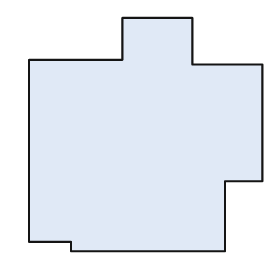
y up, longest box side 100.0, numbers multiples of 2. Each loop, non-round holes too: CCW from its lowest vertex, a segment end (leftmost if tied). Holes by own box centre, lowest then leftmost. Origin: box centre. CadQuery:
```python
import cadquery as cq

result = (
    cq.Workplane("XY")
    .moveTo(-32.0, -50.0)
    .lineTo(34.0, -50.0)
    .lineTo(34.0, -20.0)
    .lineTo(50.0, -20.0)
    .lineTo(50.0, 30.0)
    .lineTo(20.0, 30.0)
    .lineTo(20.0, 50.0)
    .lineTo(-10.0, 50.0)
    .lineTo(-10.0, 32.0)
    .lineTo(-50.0, 32.0)
    .lineTo(-50.0, -46.0)
    .lineTo(-32.0, -46.0)
    .close()
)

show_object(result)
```